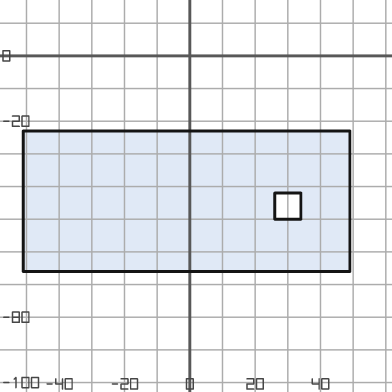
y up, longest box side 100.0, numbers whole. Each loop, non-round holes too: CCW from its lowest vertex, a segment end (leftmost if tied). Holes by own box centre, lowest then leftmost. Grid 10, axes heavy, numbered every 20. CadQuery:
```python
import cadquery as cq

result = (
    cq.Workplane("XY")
    .moveTo(-51.0, -66.0)
    .lineTo(49.0, -66.0)
    .lineTo(49.0, -23.0)
    .lineTo(-51.0, -23.0)
    .close()
    .moveTo(26.0, -50.0)
    .lineTo(34.0, -50.0)
    .lineTo(34.0, -42.0)
    .lineTo(26.0, -42.0)
    .close()
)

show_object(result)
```